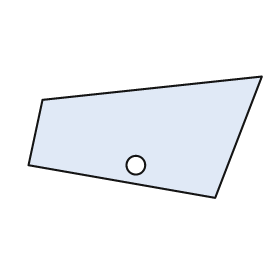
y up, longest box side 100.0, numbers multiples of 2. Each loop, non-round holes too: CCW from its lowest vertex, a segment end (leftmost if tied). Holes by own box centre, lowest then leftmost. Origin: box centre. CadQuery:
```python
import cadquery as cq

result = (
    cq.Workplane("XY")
    .moveTo(30.0, -26.0)
    .lineTo(50.0, 26.0)
    .lineTo(-44.0, 16.0)
    .lineTo(-50.0, -12.0)
    .close()
    .moveTo(-4.0, -12.0)
    .circle(4.0)
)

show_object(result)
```